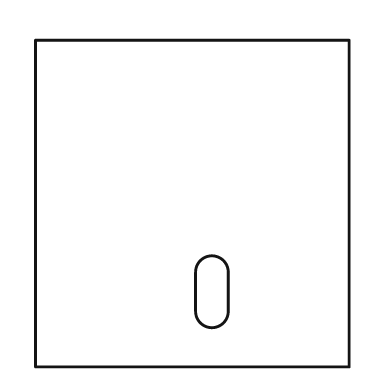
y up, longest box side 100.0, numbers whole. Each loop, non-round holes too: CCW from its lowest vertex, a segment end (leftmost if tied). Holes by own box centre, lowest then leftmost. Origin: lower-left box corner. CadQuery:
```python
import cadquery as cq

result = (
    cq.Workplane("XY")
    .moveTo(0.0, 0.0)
    .lineTo(96.0, 0.0)
    .lineTo(96.0, 100.0)
    .lineTo(0.0, 100.0)
    .close()
    .moveTo(49.0, 17.0)
    .threePointArc((54.0, 12.0), (59.0, 17.0))
    .lineTo(59.0, 29.0)
    .threePointArc((54.0, 34.0), (49.0, 29.0))
    .close()
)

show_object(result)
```